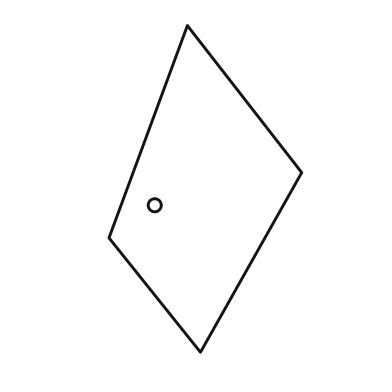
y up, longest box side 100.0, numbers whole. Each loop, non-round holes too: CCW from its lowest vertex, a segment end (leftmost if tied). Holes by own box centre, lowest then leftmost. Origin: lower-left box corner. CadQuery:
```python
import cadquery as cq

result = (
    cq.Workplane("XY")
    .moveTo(28.0, 0.0)
    .lineTo(59.0, 55.0)
    .lineTo(24.0, 100.0)
    .lineTo(0.0, 35.0)
    .close()
    .moveTo(14.0, 45.0)
    .circle(2.0)
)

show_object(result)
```